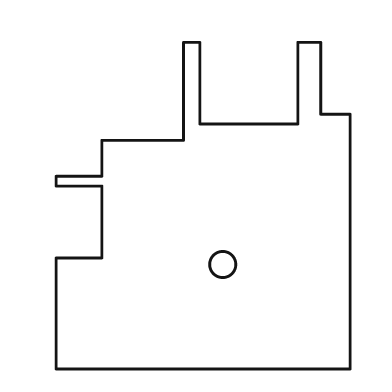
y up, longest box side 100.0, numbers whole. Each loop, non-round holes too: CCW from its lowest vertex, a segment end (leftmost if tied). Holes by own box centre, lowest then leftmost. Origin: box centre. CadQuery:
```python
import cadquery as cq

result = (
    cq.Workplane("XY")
    .moveTo(-45.0, -50.0)
    .lineTo(45.0, -50.0)
    .lineTo(45.0, 28.0)
    .lineTo(36.0, 28.0)
    .lineTo(36.0, 50.0)
    .lineTo(29.0, 50.0)
    .lineTo(29.0, 25.0)
    .lineTo(-1.0, 25.0)
    .lineTo(-1.0, 50.0)
    .lineTo(-6.0, 50.0)
    .lineTo(-6.0, 20.0)
    .lineTo(-31.0, 20.0)
    .lineTo(-31.0, 9.0)
    .lineTo(-45.0, 9.0)
    .lineTo(-45.0, 6.0)
    .lineTo(-31.0, 6.0)
    .lineTo(-31.0, -16.0)
    .lineTo(-45.0, -16.0)
    .close()
    .moveTo(6.0, -18.0)
    .circle(4.0)
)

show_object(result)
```